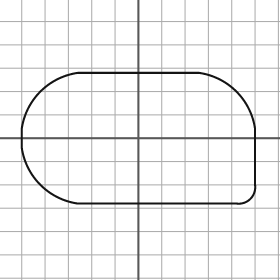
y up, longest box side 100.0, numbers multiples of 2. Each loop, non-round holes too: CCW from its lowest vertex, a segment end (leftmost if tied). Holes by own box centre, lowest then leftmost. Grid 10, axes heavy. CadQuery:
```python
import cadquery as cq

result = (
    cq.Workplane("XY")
    .moveTo(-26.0, -28.0)
    .lineTo(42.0, -28.0)
    .threePointArc((48.0, -26.0), (50.0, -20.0))
    .lineTo(50.0, 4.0)
    .threePointArc((42.0, 20.0), (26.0, 28.0))
    .lineTo(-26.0, 28.0)
    .threePointArc((-42.0, 20.0), (-50.0, 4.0))
    .lineTo(-50.0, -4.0)
    .threePointArc((-42.0, -20.0), (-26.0, -28.0))
    .close()
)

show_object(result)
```